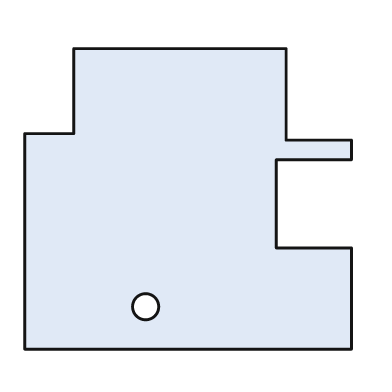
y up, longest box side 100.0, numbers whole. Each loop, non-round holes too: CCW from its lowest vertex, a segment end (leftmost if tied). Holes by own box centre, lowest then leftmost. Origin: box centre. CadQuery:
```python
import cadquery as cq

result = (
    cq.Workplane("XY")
    .moveTo(-50.0, -46.0)
    .lineTo(50.0, -46.0)
    .lineTo(50.0, -15.0)
    .lineTo(27.0, -15.0)
    .lineTo(27.0, 12.0)
    .lineTo(50.0, 12.0)
    .lineTo(50.0, 18.0)
    .lineTo(30.0, 18.0)
    .lineTo(30.0, 46.0)
    .lineTo(-35.0, 46.0)
    .lineTo(-35.0, 20.0)
    .lineTo(-50.0, 20.0)
    .close()
    .moveTo(-13.0, -33.0)
    .circle(4.0)
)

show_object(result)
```